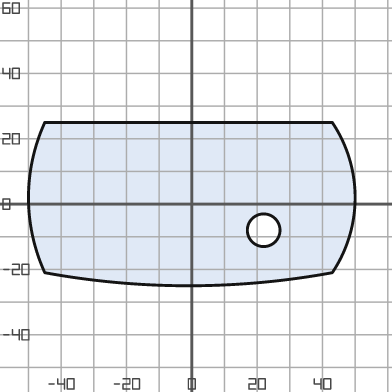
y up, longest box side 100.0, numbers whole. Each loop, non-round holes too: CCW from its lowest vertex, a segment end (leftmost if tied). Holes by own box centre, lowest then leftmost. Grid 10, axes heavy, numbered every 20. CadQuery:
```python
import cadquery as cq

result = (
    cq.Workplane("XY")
    .moveTo(-45.0, -21.0)
    .threePointArc((-1.0, -25.0), (43.0, -21.0))
    .threePointArc((50.0, 2.0), (43.0, 25.0))
    .lineTo(-45.0, 25.0)
    .threePointArc((-50.0, 2.0), (-45.0, -21.0))
    .close()
    .moveTo(22.0, -8.0)
    .circle(5.0)
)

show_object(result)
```